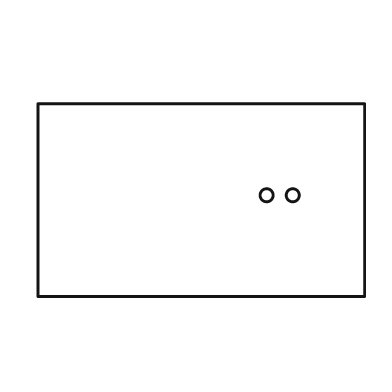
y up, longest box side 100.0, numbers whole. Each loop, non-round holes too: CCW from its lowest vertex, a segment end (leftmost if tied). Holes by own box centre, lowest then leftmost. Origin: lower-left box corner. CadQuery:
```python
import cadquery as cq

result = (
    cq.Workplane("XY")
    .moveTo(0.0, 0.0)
    .lineTo(100.0, 0.0)
    .lineTo(100.0, 59.0)
    .lineTo(0.0, 59.0)
    .close()
    .moveTo(70.0, 31.0)
    .circle(2.0)
    .moveTo(78.0, 31.0)
    .circle(2.0)
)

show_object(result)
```